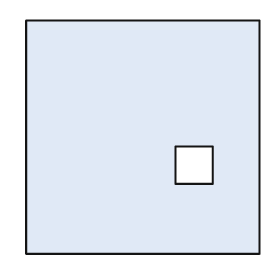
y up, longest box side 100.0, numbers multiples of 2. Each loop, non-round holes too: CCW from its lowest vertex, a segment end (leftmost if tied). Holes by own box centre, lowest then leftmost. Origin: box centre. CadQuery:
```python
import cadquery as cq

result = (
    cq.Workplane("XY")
    .moveTo(-50.0, -50.0)
    .lineTo(50.0, -50.0)
    .lineTo(50.0, 50.0)
    .lineTo(-50.0, 50.0)
    .close()
    .moveTo(14.0, -20.0)
    .lineTo(30.0, -20.0)
    .lineTo(30.0, -4.0)
    .lineTo(14.0, -4.0)
    .close()
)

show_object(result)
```